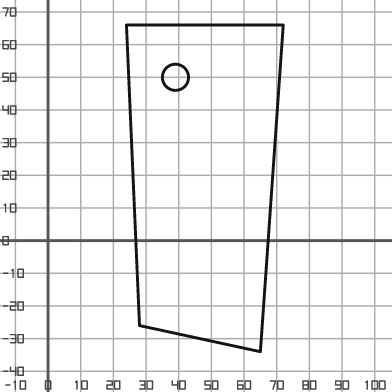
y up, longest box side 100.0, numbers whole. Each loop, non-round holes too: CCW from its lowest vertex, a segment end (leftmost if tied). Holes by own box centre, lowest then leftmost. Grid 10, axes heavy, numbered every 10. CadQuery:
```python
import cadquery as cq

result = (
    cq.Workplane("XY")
    .moveTo(65.0, -34.0)
    .lineTo(72.0, 66.0)
    .lineTo(24.0, 66.0)
    .lineTo(28.0, -26.0)
    .close()
    .moveTo(39.0, 50.0)
    .circle(4.0)
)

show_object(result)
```